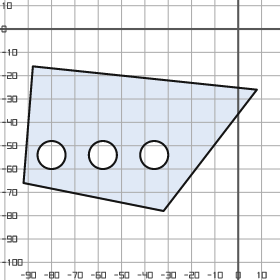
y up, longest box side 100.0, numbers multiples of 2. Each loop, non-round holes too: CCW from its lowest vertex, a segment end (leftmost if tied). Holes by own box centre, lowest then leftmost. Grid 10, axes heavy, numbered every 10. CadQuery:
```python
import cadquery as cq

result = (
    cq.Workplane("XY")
    .moveTo(-32.0, -78.0)
    .lineTo(8.0, -26.0)
    .lineTo(-88.0, -16.0)
    .lineTo(-92.0, -66.0)
    .close()
    .moveTo(-80.0, -54.0)
    .circle(6.0)
    .moveTo(-58.0, -54.0)
    .circle(6.0)
    .moveTo(-36.0, -54.0)
    .circle(6.0)
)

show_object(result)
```